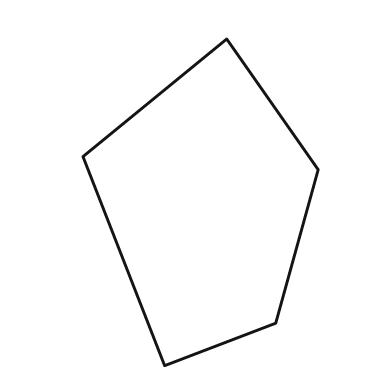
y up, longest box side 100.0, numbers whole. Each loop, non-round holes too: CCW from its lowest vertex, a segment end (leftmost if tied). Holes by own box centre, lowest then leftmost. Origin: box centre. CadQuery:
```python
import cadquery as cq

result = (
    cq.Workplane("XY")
    .moveTo(-11.0, -50.0)
    .lineTo(23.0, -37.0)
    .lineTo(36.0, 10.0)
    .lineTo(8.0, 50.0)
    .lineTo(-36.0, 14.0)
    .close()
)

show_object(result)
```